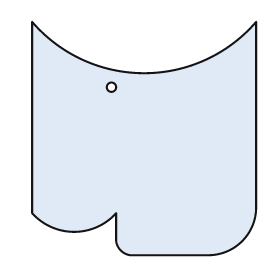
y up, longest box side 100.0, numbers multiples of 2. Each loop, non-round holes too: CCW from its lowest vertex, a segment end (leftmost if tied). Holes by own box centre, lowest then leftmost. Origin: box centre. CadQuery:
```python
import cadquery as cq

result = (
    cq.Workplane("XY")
    .moveTo(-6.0, -50.0)
    .lineTo(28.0, -50.0)
    .threePointArc((42.0, -44.0), (48.0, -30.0))
    .lineTo(48.0, 50.0)
    .threePointArc((0.0, 28.0), (-48.0, 50.0))
    .lineTo(-48.0, -32.0)
    .threePointArc((-30.0, -40.0), (-12.0, -32.0))
    .lineTo(-12.0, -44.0)
    .threePointArc((-10.0, -48.0), (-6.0, -50.0))
    .close()
    .moveTo(-14.0, 22.0)
    .circle(2.0)
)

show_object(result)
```